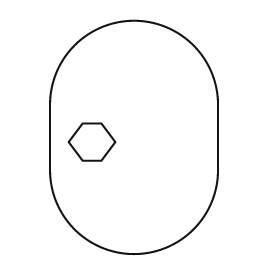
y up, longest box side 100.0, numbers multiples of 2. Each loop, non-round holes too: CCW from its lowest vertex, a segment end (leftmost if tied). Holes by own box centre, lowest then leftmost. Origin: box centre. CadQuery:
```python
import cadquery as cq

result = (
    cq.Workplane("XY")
    .moveTo(-36.0, -14.0)
    .threePointArc((0.0, -50.0), (36.0, -14.0))
    .lineTo(36.0, 14.0)
    .threePointArc((0.0, 50.0), (-36.0, 14.0))
    .close()
    .moveTo(-22.0, -10.0)
    .lineTo(-14.0, -10.0)
    .lineTo(-8.0, -2.0)
    .lineTo(-14.0, 6.0)
    .lineTo(-22.0, 6.0)
    .lineTo(-28.0, -2.0)
    .close()
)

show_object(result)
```